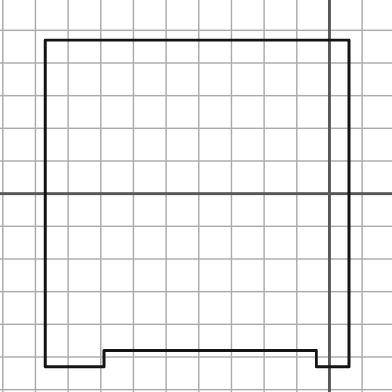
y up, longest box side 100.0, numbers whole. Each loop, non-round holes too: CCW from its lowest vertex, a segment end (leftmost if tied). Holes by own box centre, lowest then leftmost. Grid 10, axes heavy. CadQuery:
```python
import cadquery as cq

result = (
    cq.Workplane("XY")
    .moveTo(-87.0, -53.0)
    .lineTo(-69.0, -53.0)
    .lineTo(-69.0, -48.0)
    .lineTo(-4.0, -48.0)
    .lineTo(-4.0, -53.0)
    .lineTo(6.0, -53.0)
    .lineTo(6.0, 47.0)
    .lineTo(-87.0, 47.0)
    .close()
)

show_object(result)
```